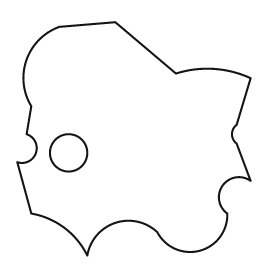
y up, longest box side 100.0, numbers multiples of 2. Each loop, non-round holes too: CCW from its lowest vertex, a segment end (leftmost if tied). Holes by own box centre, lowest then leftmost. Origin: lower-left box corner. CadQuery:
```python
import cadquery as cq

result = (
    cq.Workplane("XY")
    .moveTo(30.0, 0.0)
    .threePointArc((42.0, 14.0), (60.0, 10.0))
    .threePointArc((78.0, 2.0), (90.0, 18.0))
    .threePointArc((88.0, 30.0), (100.0, 32.0))
    .lineTo(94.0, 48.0)
    .threePointArc((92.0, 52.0), (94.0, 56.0))
    .lineTo(100.0, 76.0)
    .threePointArc((84.0, 80.0), (68.0, 78.0))
    .lineTo(42.0, 100.0)
    .lineTo(18.0, 98.0)
    .threePointArc((4.0, 84.0), (6.0, 64.0))
    .lineTo(4.0, 52.0)
    .threePointArc((8.0, 44.0), (0.0, 40.0))
    .lineTo(6.0, 18.0)
    .threePointArc((20.0, 12.0), (30.0, 0.0))
    .close()
    .moveTo(22.0, 44.0)
    .circle(8.0)
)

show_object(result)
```